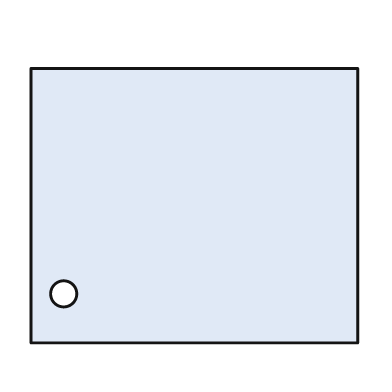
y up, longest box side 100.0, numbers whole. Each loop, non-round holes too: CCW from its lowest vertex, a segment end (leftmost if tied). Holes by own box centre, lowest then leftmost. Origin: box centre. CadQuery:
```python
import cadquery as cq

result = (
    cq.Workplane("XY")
    .moveTo(-50.0, -42.0)
    .lineTo(50.0, -42.0)
    .lineTo(50.0, 42.0)
    .lineTo(-50.0, 42.0)
    .close()
    .moveTo(-40.0, -27.0)
    .circle(4.0)
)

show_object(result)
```